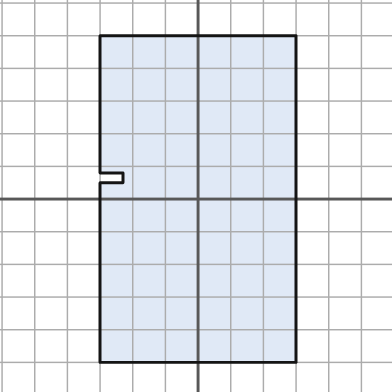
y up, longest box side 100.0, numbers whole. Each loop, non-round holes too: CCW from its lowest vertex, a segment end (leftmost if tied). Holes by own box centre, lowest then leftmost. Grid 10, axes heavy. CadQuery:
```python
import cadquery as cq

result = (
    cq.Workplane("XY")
    .moveTo(-30.0, -50.0)
    .lineTo(30.0, -50.0)
    .lineTo(30.0, 50.0)
    .lineTo(-30.0, 50.0)
    .lineTo(-30.0, 8.0)
    .lineTo(-23.0, 8.0)
    .lineTo(-23.0, 5.0)
    .lineTo(-30.0, 5.0)
    .close()
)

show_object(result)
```